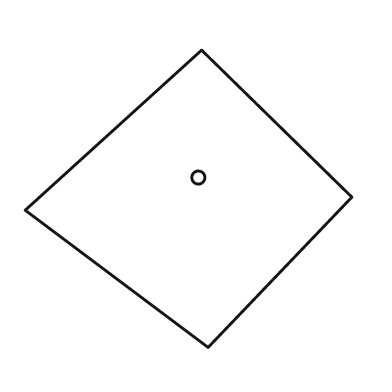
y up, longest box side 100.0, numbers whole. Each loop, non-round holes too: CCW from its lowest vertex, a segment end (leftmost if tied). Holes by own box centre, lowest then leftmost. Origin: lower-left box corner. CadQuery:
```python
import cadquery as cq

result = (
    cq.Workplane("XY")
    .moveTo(56.0, 0.0)
    .lineTo(100.0, 46.0)
    .lineTo(54.0, 91.0)
    .lineTo(0.0, 42.0)
    .close()
    .moveTo(53.0, 52.0)
    .circle(2.0)
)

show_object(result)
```